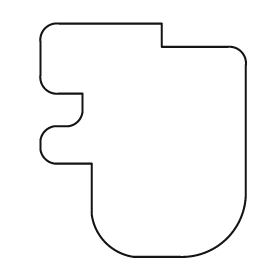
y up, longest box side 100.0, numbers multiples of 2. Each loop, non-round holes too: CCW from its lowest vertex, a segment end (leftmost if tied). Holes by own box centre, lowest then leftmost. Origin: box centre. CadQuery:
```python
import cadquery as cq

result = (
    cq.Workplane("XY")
    .moveTo(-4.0, -50.0)
    .lineTo(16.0, -50.0)
    .threePointArc((36.0, -42.0), (44.0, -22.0))
    .lineTo(44.0, 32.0)
    .threePointArc((42.0, 38.0), (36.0, 40.0))
    .lineTo(8.0, 40.0)
    .lineTo(8.0, 50.0)
    .lineTo(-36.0, 50.0)
    .threePointArc((-42.0, 48.0), (-44.0, 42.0))
    .lineTo(-44.0, 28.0)
    .threePointArc((-42.0, 22.0), (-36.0, 20.0))
    .lineTo(-26.0, 20.0)
    .lineTo(-26.0, 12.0)
    .threePointArc((-28.0, 8.0), (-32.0, 6.0))
    .lineTo(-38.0, 6.0)
    .threePointArc((-42.0, 4.0), (-44.0, 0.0))
    .lineTo(-44.0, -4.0)
    .threePointArc((-42.0, -8.0), (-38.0, -10.0))
    .lineTo(-22.0, -10.0)
    .lineTo(-22.0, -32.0)
    .threePointArc((-16.0, -44.0), (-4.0, -50.0))
    .close()
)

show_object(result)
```